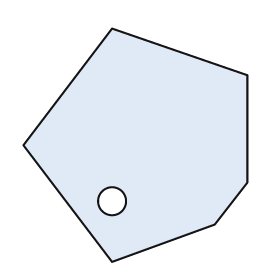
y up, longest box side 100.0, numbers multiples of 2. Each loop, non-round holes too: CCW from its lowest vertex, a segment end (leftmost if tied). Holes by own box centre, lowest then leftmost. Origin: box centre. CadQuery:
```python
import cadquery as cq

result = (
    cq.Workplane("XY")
    .moveTo(-10.0, -50.0)
    .lineTo(34.0, -34.0)
    .lineTo(48.0, -16.0)
    .lineTo(48.0, 30.0)
    .lineTo(-10.0, 50.0)
    .lineTo(-48.0, 0.0)
    .close()
    .moveTo(-10.0, -24.0)
    .circle(6.0)
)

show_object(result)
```